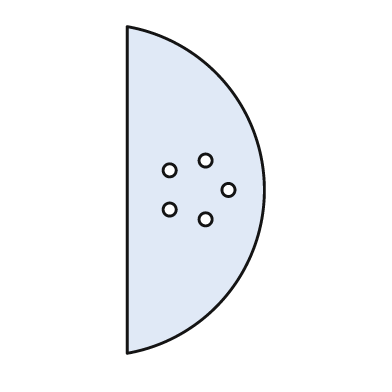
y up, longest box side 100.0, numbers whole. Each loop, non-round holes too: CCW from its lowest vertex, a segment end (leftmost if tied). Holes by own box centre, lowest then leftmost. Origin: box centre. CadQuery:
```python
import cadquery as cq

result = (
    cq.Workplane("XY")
    .moveTo(-21.0, -50.0)
    .threePointArc((21.0, 0.0), (-21.0, 50.0))
    .close()
    .moveTo(3.0, -9.0)
    .circle(2.0)
    .moveTo(-8.0, -6.0)
    .circle(2.0)
    .moveTo(10.0, 0.0)
    .circle(2.0)
    .moveTo(-8.0, 6.0)
    .circle(2.0)
    .moveTo(3.0, 9.0)
    .circle(2.0)
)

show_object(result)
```